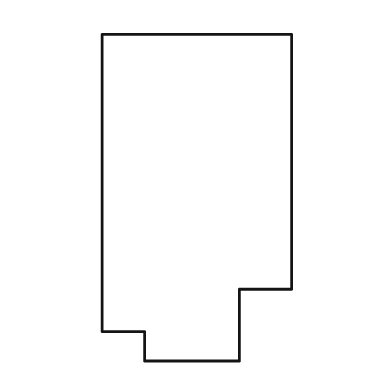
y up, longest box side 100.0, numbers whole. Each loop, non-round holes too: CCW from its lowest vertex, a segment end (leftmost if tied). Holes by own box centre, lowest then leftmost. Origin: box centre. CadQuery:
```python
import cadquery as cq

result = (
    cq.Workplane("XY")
    .moveTo(-16.0, -50.0)
    .lineTo(13.0, -50.0)
    .lineTo(13.0, -28.0)
    .lineTo(29.0, -28.0)
    .lineTo(29.0, 50.0)
    .lineTo(-29.0, 50.0)
    .lineTo(-29.0, -41.0)
    .lineTo(-16.0, -41.0)
    .close()
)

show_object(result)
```